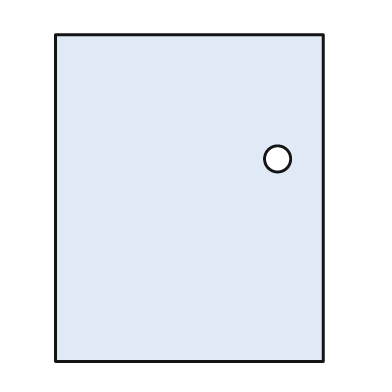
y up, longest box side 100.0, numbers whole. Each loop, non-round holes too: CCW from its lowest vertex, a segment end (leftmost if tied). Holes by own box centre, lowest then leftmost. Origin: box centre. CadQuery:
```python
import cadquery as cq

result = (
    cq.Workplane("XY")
    .moveTo(-41.0, -50.0)
    .lineTo(41.0, -50.0)
    .lineTo(41.0, 50.0)
    .lineTo(-41.0, 50.0)
    .close()
    .moveTo(27.0, 12.0)
    .circle(4.0)
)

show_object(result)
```